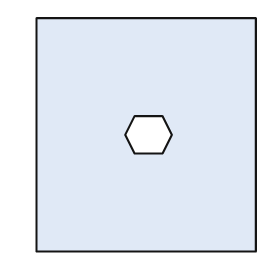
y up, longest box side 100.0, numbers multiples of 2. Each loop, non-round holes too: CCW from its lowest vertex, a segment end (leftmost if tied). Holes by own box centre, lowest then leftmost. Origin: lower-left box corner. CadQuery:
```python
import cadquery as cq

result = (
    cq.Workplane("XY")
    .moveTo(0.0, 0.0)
    .lineTo(94.0, 0.0)
    .lineTo(94.0, 100.0)
    .lineTo(0.0, 100.0)
    .close()
    .moveTo(42.0, 42.0)
    .lineTo(54.0, 42.0)
    .lineTo(58.0, 50.0)
    .lineTo(54.0, 58.0)
    .lineTo(42.0, 58.0)
    .lineTo(38.0, 50.0)
    .close()
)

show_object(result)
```